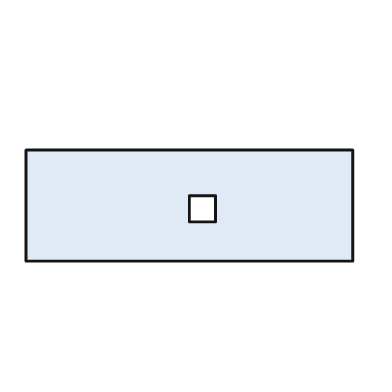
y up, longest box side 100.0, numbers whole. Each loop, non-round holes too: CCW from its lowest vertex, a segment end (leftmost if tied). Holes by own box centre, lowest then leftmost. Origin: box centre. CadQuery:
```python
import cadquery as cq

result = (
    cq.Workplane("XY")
    .moveTo(-50.0, -17.0)
    .lineTo(50.0, -17.0)
    .lineTo(50.0, 17.0)
    .lineTo(-50.0, 17.0)
    .close()
    .moveTo(0.0, -5.0)
    .lineTo(8.0, -5.0)
    .lineTo(8.0, 3.0)
    .lineTo(0.0, 3.0)
    .close()
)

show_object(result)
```